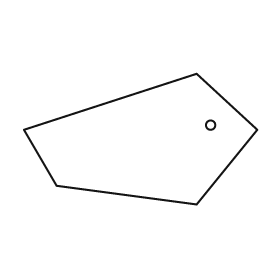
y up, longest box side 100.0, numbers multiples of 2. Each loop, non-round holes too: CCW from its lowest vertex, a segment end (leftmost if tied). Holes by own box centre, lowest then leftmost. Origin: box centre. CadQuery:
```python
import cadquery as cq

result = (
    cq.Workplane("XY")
    .moveTo(24.0, -28.0)
    .lineTo(50.0, 4.0)
    .lineTo(24.0, 28.0)
    .lineTo(-50.0, 4.0)
    .lineTo(-36.0, -20.0)
    .close()
    .moveTo(30.0, 6.0)
    .circle(2.0)
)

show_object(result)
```